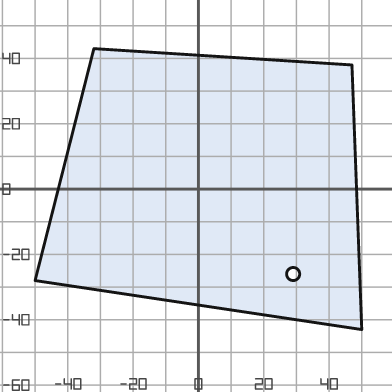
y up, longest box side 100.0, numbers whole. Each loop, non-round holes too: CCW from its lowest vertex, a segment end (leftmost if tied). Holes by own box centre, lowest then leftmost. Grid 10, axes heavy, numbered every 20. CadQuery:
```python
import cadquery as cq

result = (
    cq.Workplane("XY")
    .moveTo(50.0, -43.0)
    .lineTo(47.0, 38.0)
    .lineTo(-32.0, 43.0)
    .lineTo(-50.0, -28.0)
    .close()
    .moveTo(29.0, -26.0)
    .circle(2.0)
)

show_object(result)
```